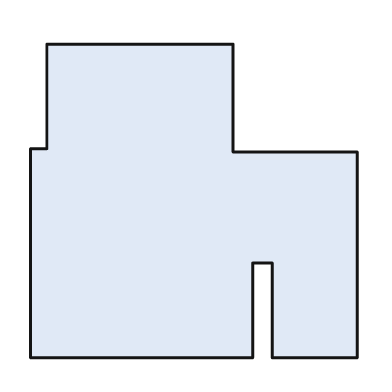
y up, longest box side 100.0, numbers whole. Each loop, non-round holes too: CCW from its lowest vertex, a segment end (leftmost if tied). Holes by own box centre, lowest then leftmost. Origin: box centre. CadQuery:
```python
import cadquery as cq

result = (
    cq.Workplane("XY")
    .moveTo(-50.0, -48.0)
    .lineTo(18.0, -48.0)
    .lineTo(18.0, -19.0)
    .lineTo(24.0, -19.0)
    .lineTo(24.0, -48.0)
    .lineTo(50.0, -48.0)
    .lineTo(50.0, 15.0)
    .lineTo(12.0, 15.0)
    .lineTo(12.0, 48.0)
    .lineTo(-45.0, 48.0)
    .lineTo(-45.0, 16.0)
    .lineTo(-50.0, 16.0)
    .close()
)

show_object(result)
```